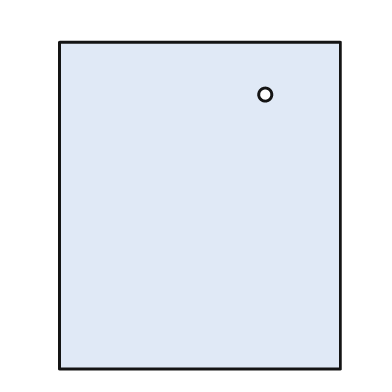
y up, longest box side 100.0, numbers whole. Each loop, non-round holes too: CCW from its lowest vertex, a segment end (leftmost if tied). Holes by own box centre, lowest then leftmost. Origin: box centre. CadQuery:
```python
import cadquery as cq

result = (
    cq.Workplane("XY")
    .moveTo(-43.0, -50.0)
    .lineTo(43.0, -50.0)
    .lineTo(43.0, 50.0)
    .lineTo(-43.0, 50.0)
    .close()
    .moveTo(20.0, 34.0)
    .circle(2.0)
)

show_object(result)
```